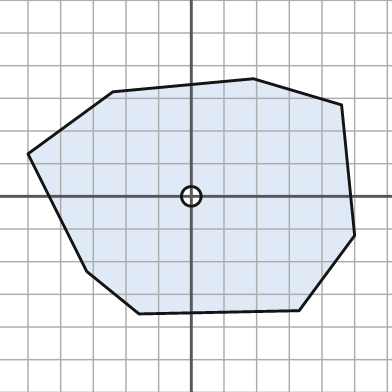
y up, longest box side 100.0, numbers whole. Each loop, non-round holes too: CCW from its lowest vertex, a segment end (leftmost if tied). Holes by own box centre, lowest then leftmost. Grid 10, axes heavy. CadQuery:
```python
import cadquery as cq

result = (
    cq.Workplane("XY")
    .moveTo(-16.0, -36.0)
    .lineTo(33.0, -35.0)
    .lineTo(50.0, -12.0)
    .lineTo(46.0, 28.0)
    .lineTo(19.0, 36.0)
    .lineTo(-24.0, 32.0)
    .lineTo(-50.0, 13.0)
    .lineTo(-32.0, -23.0)
    .close()
    .moveTo(0.0, 0.0)
    .circle(3.0)
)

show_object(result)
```